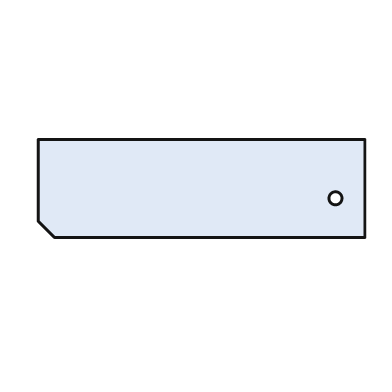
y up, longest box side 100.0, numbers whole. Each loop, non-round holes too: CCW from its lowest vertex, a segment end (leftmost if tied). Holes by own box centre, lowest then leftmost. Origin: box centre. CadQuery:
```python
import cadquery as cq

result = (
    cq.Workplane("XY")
    .moveTo(-45.0, -15.0)
    .lineTo(50.0, -15.0)
    .lineTo(50.0, 15.0)
    .lineTo(-50.0, 15.0)
    .lineTo(-50.0, -10.0)
    .close()
    .moveTo(41.0, -3.0)
    .circle(2.0)
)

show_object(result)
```